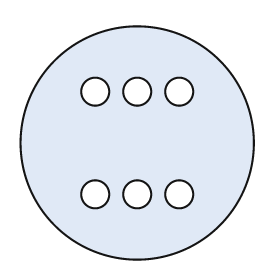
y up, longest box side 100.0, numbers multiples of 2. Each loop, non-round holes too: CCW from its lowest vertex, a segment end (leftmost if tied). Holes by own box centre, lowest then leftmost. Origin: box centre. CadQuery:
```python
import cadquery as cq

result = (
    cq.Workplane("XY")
    .moveTo(0.0, 0.0)
    .circle(50.0)
    .moveTo(-18.0, -22.0)
    .circle(6.0)
    .moveTo(0.0, -22.0)
    .circle(6.0)
    .moveTo(18.0, -22.0)
    .circle(6.0)
    .moveTo(-18.0, 22.0)
    .circle(6.0)
    .moveTo(0.0, 22.0)
    .circle(6.0)
    .moveTo(18.0, 22.0)
    .circle(6.0)
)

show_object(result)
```